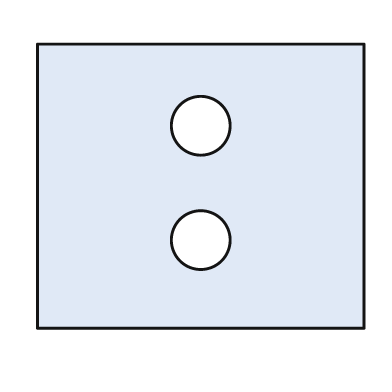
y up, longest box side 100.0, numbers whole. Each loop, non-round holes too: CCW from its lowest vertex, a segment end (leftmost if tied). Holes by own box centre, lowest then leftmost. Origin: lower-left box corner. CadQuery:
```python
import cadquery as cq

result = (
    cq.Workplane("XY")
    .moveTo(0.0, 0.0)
    .lineTo(100.0, 0.0)
    .lineTo(100.0, 87.0)
    .lineTo(0.0, 87.0)
    .close()
    .moveTo(50.0, 27.0)
    .circle(9.0)
    .moveTo(50.0, 62.0)
    .circle(9.0)
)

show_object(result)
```